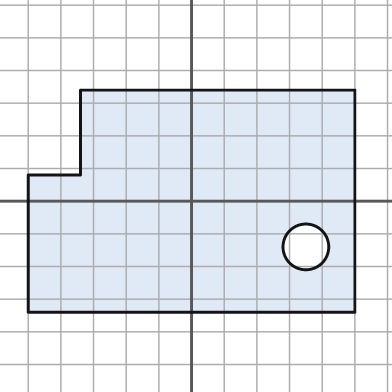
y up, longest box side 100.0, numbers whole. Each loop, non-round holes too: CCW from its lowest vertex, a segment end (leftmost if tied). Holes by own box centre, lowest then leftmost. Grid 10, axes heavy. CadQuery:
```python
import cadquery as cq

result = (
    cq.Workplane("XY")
    .moveTo(-50.0, -34.0)
    .lineTo(50.0, -34.0)
    .lineTo(50.0, 34.0)
    .lineTo(-34.0, 34.0)
    .lineTo(-34.0, 8.0)
    .lineTo(-50.0, 8.0)
    .close()
    .moveTo(35.0, -14.0)
    .circle(7.0)
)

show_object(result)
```